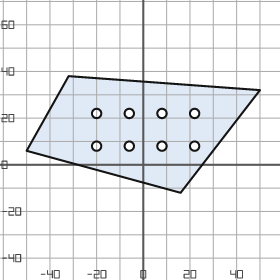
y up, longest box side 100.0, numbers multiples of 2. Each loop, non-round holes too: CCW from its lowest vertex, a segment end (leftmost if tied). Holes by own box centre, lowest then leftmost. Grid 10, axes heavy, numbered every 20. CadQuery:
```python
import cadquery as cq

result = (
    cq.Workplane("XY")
    .moveTo(16.0, -12.0)
    .lineTo(50.0, 32.0)
    .lineTo(-32.0, 38.0)
    .lineTo(-50.0, 6.0)
    .close()
    .moveTo(-20.0, 8.0)
    .circle(2.0)
    .moveTo(-6.0, 8.0)
    .circle(2.0)
    .moveTo(8.0, 8.0)
    .circle(2.0)
    .moveTo(22.0, 8.0)
    .circle(2.0)
    .moveTo(-20.0, 22.0)
    .circle(2.0)
    .moveTo(-6.0, 22.0)
    .circle(2.0)
    .moveTo(8.0, 22.0)
    .circle(2.0)
    .moveTo(22.0, 22.0)
    .circle(2.0)
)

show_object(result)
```